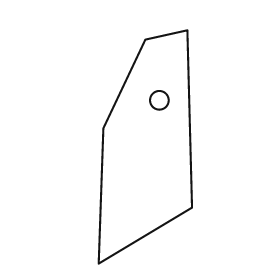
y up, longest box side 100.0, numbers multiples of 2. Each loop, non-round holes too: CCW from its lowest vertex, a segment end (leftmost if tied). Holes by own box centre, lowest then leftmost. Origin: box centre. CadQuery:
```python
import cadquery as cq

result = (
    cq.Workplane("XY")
    .moveTo(-20.0, -50.0)
    .lineTo(20.0, -26.0)
    .lineTo(18.0, 50.0)
    .lineTo(0.0, 46.0)
    .lineTo(-18.0, 8.0)
    .close()
    .moveTo(6.0, 20.0)
    .circle(4.0)
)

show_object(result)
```